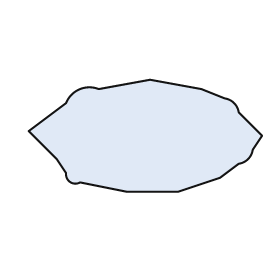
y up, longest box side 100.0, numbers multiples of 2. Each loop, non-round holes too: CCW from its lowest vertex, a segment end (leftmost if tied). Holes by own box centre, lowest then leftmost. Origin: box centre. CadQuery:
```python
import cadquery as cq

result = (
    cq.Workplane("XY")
    .moveTo(-8.0, -24.0)
    .lineTo(14.0, -24.0)
    .lineTo(32.0, -18.0)
    .lineTo(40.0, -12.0)
    .threePointArc((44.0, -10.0), (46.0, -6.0))
    .lineTo(50.0, 0.0)
    .lineTo(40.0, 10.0)
    .threePointArc((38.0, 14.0), (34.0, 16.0))
    .lineTo(24.0, 20.0)
    .lineTo(2.0, 24.0)
    .lineTo(-20.0, 20.0)
    .threePointArc((-28.0, 20.0), (-34.0, 14.0))
    .lineTo(-50.0, 2.0)
    .lineTo(-38.0, -10.0)
    .lineTo(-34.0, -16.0)
    .threePointArc((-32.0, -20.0), (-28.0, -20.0))
    .close()
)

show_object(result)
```